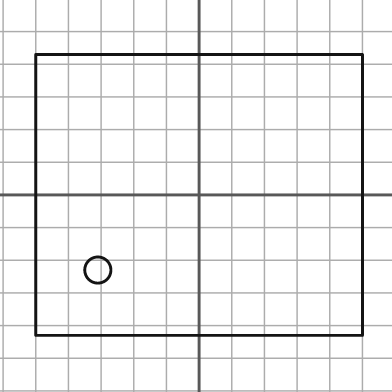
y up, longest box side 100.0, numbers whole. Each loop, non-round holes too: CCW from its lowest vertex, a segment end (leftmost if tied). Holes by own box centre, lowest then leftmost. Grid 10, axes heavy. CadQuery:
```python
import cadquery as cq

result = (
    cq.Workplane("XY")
    .moveTo(-50.0, -43.0)
    .lineTo(50.0, -43.0)
    .lineTo(50.0, 43.0)
    .lineTo(-50.0, 43.0)
    .close()
    .moveTo(-31.0, -23.0)
    .circle(4.0)
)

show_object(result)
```